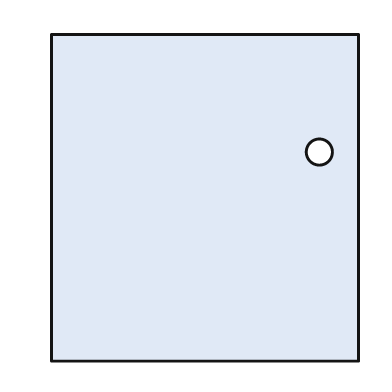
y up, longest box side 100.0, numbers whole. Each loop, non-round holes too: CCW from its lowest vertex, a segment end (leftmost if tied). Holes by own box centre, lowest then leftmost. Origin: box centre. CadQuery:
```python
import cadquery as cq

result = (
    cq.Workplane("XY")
    .moveTo(-47.0, -50.0)
    .lineTo(47.0, -50.0)
    .lineTo(47.0, 50.0)
    .lineTo(-47.0, 50.0)
    .close()
    .moveTo(35.0, 14.0)
    .circle(4.0)
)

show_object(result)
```